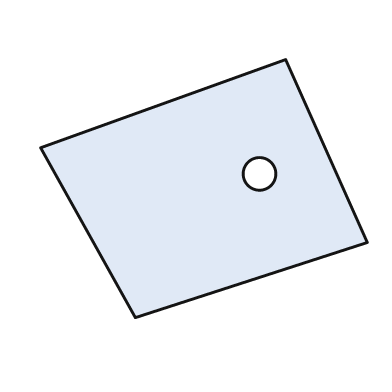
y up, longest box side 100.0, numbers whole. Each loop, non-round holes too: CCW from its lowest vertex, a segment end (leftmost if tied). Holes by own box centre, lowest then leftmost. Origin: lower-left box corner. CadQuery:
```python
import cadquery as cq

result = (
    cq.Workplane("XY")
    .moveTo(29.0, 0.0)
    .lineTo(100.0, 23.0)
    .lineTo(75.0, 79.0)
    .lineTo(0.0, 52.0)
    .close()
    .moveTo(67.0, 44.0)
    .circle(5.0)
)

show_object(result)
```